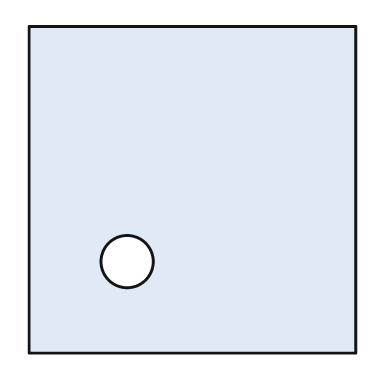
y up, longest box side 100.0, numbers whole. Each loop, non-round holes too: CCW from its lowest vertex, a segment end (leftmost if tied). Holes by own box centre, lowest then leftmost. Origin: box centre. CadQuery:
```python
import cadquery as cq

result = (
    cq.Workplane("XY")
    .moveTo(-50.0, -50.0)
    .lineTo(50.0, -50.0)
    .lineTo(50.0, 50.0)
    .lineTo(-50.0, 50.0)
    .close()
    .moveTo(-20.0, -22.0)
    .circle(8.0)
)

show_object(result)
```